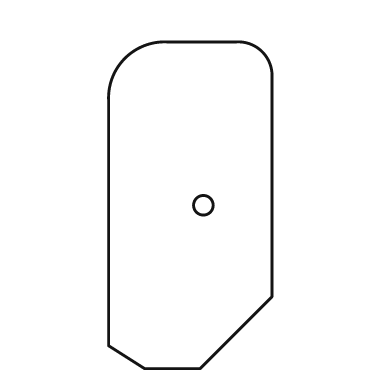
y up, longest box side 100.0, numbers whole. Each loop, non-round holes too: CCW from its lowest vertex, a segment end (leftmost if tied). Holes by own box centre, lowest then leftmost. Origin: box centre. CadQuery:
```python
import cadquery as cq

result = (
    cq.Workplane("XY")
    .moveTo(-14.0, -50.0)
    .lineTo(3.0, -50.0)
    .lineTo(25.0, -28.0)
    .lineTo(25.0, 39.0)
    .threePointArc((22.0, 47.0), (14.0, 50.0))
    .lineTo(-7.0, 50.0)
    .threePointArc((-20.0, 45.0), (-25.0, 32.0))
    .lineTo(-25.0, -43.0)
    .close()
    .moveTo(4.0, 0.0)
    .circle(3.0)
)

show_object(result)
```